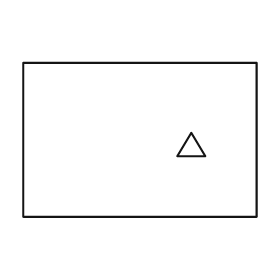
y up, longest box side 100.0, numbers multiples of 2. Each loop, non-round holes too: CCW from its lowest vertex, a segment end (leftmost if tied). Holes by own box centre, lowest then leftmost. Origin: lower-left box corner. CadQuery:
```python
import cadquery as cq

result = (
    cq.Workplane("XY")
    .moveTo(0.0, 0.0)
    .lineTo(100.0, 0.0)
    .lineTo(100.0, 66.0)
    .lineTo(0.0, 66.0)
    .close()
    .moveTo(66.0, 26.0)
    .lineTo(78.0, 26.0)
    .lineTo(72.0, 36.0)
    .close()
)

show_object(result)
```